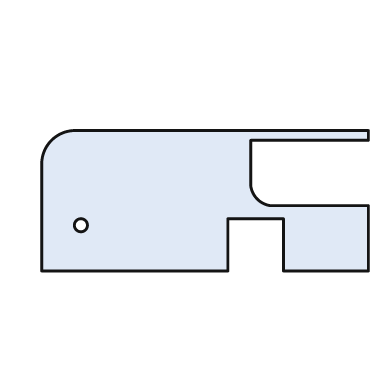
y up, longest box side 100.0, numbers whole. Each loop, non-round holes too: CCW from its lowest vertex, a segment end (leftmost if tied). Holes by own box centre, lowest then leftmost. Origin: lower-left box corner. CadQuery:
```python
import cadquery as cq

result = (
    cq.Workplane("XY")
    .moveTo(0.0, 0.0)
    .lineTo(57.0, 0.0)
    .lineTo(57.0, 16.0)
    .lineTo(74.0, 16.0)
    .lineTo(74.0, 0.0)
    .lineTo(100.0, 0.0)
    .lineTo(100.0, 20.0)
    .lineTo(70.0, 20.0)
    .threePointArc((66.0, 22.0), (64.0, 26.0))
    .lineTo(64.0, 40.0)
    .lineTo(100.0, 40.0)
    .lineTo(100.0, 43.0)
    .lineTo(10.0, 43.0)
    .threePointArc((3.0, 40.0), (0.0, 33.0))
    .close()
    .moveTo(12.0, 14.0)
    .circle(2.0)
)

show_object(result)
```